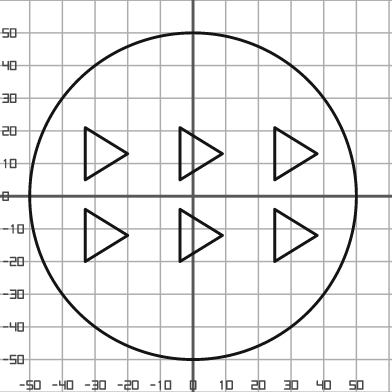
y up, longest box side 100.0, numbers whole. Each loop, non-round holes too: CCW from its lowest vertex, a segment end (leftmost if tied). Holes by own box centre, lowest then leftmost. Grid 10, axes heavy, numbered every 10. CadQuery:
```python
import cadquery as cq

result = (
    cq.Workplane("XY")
    .moveTo(0.0, 0.0)
    .circle(50.0)
    .moveTo(-33.0, -20.0)
    .lineTo(-20.0, -12.0)
    .lineTo(-33.0, -4.0)
    .close()
    .moveTo(-4.0, -20.0)
    .lineTo(9.0, -12.0)
    .lineTo(-4.0, -4.0)
    .close()
    .moveTo(25.0, -20.0)
    .lineTo(38.0, -12.0)
    .lineTo(25.0, -4.0)
    .close()
    .moveTo(-33.0, 5.0)
    .lineTo(-20.0, 13.0)
    .lineTo(-33.0, 21.0)
    .close()
    .moveTo(-4.0, 5.0)
    .lineTo(9.0, 13.0)
    .lineTo(-4.0, 21.0)
    .close()
    .moveTo(25.0, 5.0)
    .lineTo(38.0, 13.0)
    .lineTo(25.0, 21.0)
    .close()
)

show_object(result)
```